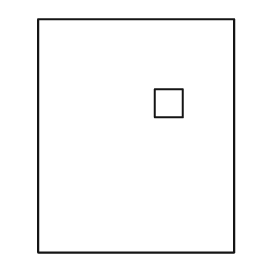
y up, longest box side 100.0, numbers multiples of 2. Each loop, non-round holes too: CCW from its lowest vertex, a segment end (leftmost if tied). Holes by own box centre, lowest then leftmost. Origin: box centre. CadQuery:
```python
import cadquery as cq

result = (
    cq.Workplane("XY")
    .moveTo(-42.0, -50.0)
    .lineTo(42.0, -50.0)
    .lineTo(42.0, 50.0)
    .lineTo(-42.0, 50.0)
    .close()
    .moveTo(8.0, 8.0)
    .lineTo(20.0, 8.0)
    .lineTo(20.0, 20.0)
    .lineTo(8.0, 20.0)
    .close()
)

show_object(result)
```